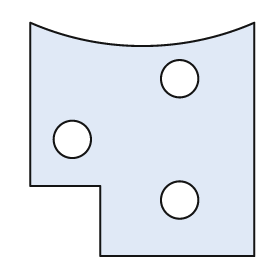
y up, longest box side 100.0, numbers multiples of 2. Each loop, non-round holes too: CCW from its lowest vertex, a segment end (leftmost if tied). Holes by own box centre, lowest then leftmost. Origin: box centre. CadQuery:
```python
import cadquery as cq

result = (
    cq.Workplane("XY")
    .moveTo(-18.0, -50.0)
    .lineTo(48.0, -50.0)
    .lineTo(48.0, 50.0)
    .threePointArc((0.0, 40.0), (-48.0, 50.0))
    .lineTo(-48.0, -20.0)
    .lineTo(-18.0, -20.0)
    .close()
    .moveTo(16.0, -26.0)
    .circle(8.0)
    .moveTo(-30.0, 0.0)
    .circle(8.0)
    .moveTo(16.0, 26.0)
    .circle(8.0)
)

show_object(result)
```